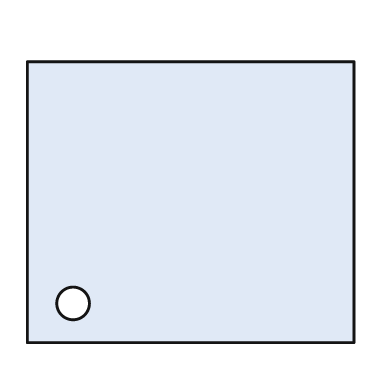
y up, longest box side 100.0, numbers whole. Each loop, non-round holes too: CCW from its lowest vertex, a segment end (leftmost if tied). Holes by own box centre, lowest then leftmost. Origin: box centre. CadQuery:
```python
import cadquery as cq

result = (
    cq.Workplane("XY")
    .moveTo(-50.0, -43.0)
    .lineTo(50.0, -43.0)
    .lineTo(50.0, 43.0)
    .lineTo(-50.0, 43.0)
    .close()
    .moveTo(-36.0, -31.0)
    .circle(5.0)
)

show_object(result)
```